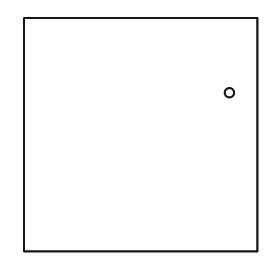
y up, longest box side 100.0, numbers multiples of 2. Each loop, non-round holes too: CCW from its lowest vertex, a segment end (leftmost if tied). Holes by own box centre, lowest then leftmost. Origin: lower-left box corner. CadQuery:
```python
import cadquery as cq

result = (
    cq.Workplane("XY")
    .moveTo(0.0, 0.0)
    .lineTo(100.0, 0.0)
    .lineTo(100.0, 100.0)
    .lineTo(0.0, 100.0)
    .close()
    .moveTo(88.0, 68.0)
    .circle(2.0)
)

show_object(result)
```